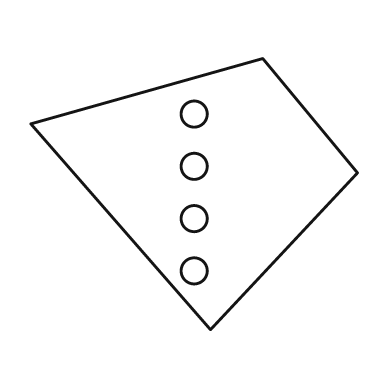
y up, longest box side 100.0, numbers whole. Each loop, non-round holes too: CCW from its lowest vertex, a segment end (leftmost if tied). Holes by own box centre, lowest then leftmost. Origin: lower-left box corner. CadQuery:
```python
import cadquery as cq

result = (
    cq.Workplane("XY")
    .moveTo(55.0, 0.0)
    .lineTo(100.0, 48.0)
    .lineTo(71.0, 83.0)
    .lineTo(0.0, 63.0)
    .close()
    .moveTo(50.0, 18.0)
    .circle(4.0)
    .moveTo(50.0, 34.0)
    .circle(4.0)
    .moveTo(50.0, 50.0)
    .circle(4.0)
    .moveTo(50.0, 66.0)
    .circle(4.0)
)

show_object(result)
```